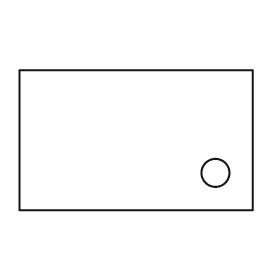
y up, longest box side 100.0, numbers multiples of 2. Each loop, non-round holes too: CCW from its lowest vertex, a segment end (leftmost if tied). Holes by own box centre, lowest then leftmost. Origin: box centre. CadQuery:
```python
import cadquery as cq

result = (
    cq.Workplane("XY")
    .moveTo(-50.0, -30.0)
    .lineTo(50.0, -30.0)
    .lineTo(50.0, 30.0)
    .lineTo(-50.0, 30.0)
    .close()
    .moveTo(34.0, -14.0)
    .circle(6.0)
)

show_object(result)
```